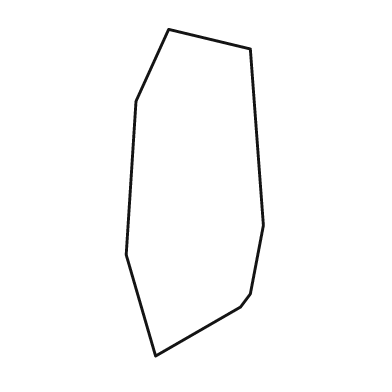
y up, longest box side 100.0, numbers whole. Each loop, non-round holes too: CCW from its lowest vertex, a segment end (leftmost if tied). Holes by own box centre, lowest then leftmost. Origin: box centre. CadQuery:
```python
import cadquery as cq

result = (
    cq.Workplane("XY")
    .moveTo(-12.0, -50.0)
    .lineTo(14.0, -35.0)
    .lineTo(17.0, -31.0)
    .lineTo(21.0, -10.0)
    .lineTo(17.0, 44.0)
    .lineTo(-8.0, 50.0)
    .lineTo(-18.0, 28.0)
    .lineTo(-21.0, -19.0)
    .close()
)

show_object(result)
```